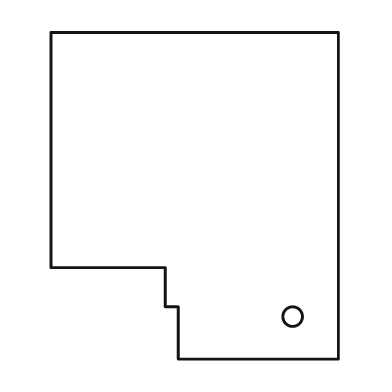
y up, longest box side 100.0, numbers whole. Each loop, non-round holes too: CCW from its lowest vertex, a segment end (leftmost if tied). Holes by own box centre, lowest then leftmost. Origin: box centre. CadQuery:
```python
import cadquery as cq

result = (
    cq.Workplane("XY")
    .moveTo(-5.0, -50.0)
    .lineTo(44.0, -50.0)
    .lineTo(44.0, 50.0)
    .lineTo(-44.0, 50.0)
    .lineTo(-44.0, -22.0)
    .lineTo(-9.0, -22.0)
    .lineTo(-9.0, -34.0)
    .lineTo(-5.0, -34.0)
    .close()
    .moveTo(30.0, -37.0)
    .circle(3.0)
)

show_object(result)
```